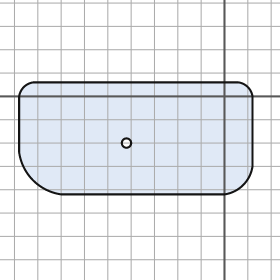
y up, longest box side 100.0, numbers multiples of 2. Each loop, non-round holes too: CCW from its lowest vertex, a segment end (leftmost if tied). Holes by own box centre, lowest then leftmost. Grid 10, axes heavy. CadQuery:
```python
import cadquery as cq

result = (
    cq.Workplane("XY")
    .moveTo(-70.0, -42.0)
    .lineTo(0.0, -42.0)
    .threePointArc((8.0, -38.0), (12.0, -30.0))
    .lineTo(12.0, 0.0)
    .threePointArc((10.0, 4.0), (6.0, 6.0))
    .lineTo(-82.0, 6.0)
    .threePointArc((-86.0, 4.0), (-88.0, 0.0))
    .lineTo(-88.0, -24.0)
    .threePointArc((-82.0, -36.0), (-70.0, -42.0))
    .close()
    .moveTo(-42.0, -20.0)
    .circle(2.0)
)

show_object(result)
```